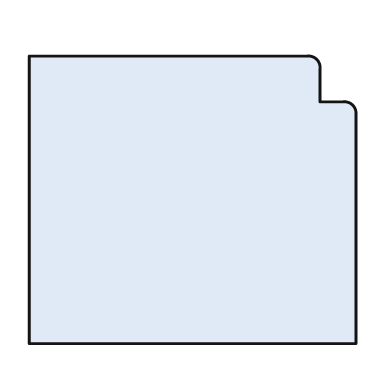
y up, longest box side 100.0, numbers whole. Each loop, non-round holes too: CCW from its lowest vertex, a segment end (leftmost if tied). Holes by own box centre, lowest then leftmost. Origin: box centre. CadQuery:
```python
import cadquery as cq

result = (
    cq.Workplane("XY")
    .moveTo(-50.0, -44.0)
    .lineTo(50.0, -44.0)
    .lineTo(50.0, 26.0)
    .threePointArc((49.0, 29.0), (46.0, 30.0))
    .lineTo(39.0, 30.0)
    .lineTo(39.0, 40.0)
    .threePointArc((38.0, 43.0), (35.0, 44.0))
    .lineTo(-50.0, 44.0)
    .close()
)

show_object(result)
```